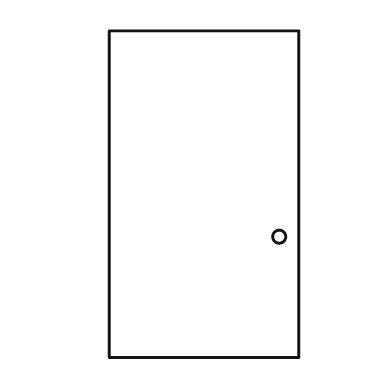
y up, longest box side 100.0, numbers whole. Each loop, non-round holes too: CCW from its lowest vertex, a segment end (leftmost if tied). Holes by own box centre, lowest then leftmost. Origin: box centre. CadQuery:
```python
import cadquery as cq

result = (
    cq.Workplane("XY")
    .moveTo(-29.0, -50.0)
    .lineTo(29.0, -50.0)
    .lineTo(29.0, 50.0)
    .lineTo(-29.0, 50.0)
    .close()
    .moveTo(23.0, -13.0)
    .circle(2.0)
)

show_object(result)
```